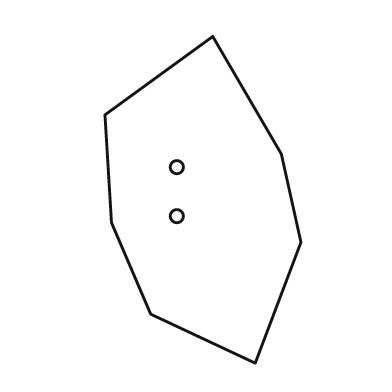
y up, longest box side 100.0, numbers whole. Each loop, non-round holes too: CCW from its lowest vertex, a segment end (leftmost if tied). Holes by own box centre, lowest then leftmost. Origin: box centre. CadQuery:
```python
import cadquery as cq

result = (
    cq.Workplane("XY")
    .moveTo(16.0, -50.0)
    .lineTo(30.0, -13.0)
    .lineTo(24.0, 14.0)
    .lineTo(3.0, 50.0)
    .lineTo(-30.0, 26.0)
    .lineTo(-28.0, -7.0)
    .lineTo(-16.0, -35.0)
    .close()
    .moveTo(-8.0, -5.0)
    .circle(2.0)
    .moveTo(-8.0, 10.0)
    .circle(2.0)
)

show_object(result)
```